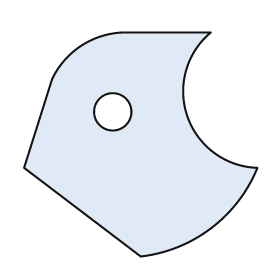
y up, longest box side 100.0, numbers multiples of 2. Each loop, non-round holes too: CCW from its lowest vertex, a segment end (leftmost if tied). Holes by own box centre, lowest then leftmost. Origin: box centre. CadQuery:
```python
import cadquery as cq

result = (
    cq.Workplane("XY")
    .moveTo(0.0, -48.0)
    .threePointArc((30.0, -36.0), (50.0, -10.0))
    .threePointArc((20.0, 12.0), (30.0, 48.0))
    .lineTo(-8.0, 48.0)
    .threePointArc((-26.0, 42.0), (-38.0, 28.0))
    .lineTo(-50.0, -10.0)
    .close()
    .moveTo(-12.0, 14.0)
    .circle(8.0)
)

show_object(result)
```